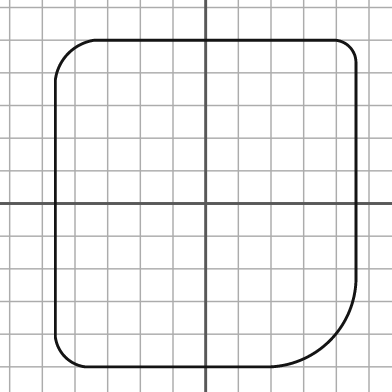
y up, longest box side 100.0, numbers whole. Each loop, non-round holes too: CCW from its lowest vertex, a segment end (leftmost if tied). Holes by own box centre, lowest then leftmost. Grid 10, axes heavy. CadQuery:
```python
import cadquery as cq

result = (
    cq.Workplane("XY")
    .moveTo(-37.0, -50.0)
    .lineTo(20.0, -50.0)
    .threePointArc((38.0, -42.0), (46.0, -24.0))
    .lineTo(46.0, 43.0)
    .threePointArc((44.0, 48.0), (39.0, 50.0))
    .lineTo(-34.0, 50.0)
    .threePointArc((-42.0, 46.0), (-46.0, 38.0))
    .lineTo(-46.0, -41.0)
    .threePointArc((-43.0, -47.0), (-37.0, -50.0))
    .close()
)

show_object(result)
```